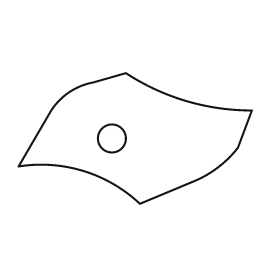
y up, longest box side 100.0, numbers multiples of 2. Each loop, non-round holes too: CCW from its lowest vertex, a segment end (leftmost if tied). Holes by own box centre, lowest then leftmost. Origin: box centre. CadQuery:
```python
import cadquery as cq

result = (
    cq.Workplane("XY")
    .moveTo(2.0, -28.0)
    .lineTo(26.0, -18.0)
    .threePointArc((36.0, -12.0), (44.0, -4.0))
    .lineTo(50.0, 12.0)
    .threePointArc((22.0, 16.0), (-4.0, 28.0))
    .lineTo(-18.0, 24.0)
    .threePointArc((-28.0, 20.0), (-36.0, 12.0))
    .lineTo(-50.0, -12.0)
    .threePointArc((-22.0, -14.0), (2.0, -28.0))
    .close()
    .moveTo(-10.0, 0.0)
    .circle(6.0)
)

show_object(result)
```